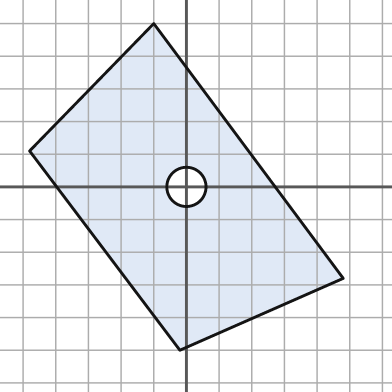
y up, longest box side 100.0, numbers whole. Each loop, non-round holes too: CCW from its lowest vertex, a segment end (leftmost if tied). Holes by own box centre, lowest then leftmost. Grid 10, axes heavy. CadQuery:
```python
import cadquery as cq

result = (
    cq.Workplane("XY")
    .moveTo(-2.0, -50.0)
    .lineTo(48.0, -28.0)
    .lineTo(-10.0, 50.0)
    .lineTo(-48.0, 11.0)
    .close()
    .moveTo(0.0, 0.0)
    .circle(6.0)
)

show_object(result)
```